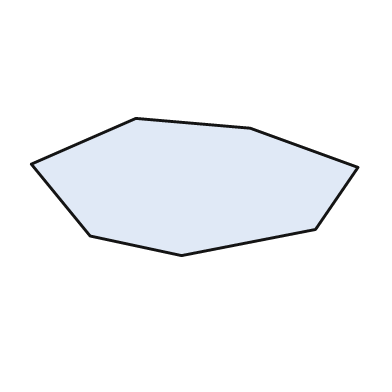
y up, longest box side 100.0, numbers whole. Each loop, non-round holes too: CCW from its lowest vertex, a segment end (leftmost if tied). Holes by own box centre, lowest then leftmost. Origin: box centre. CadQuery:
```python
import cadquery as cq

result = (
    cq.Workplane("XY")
    .moveTo(-4.0, -21.0)
    .lineTo(37.0, -13.0)
    .lineTo(50.0, 6.0)
    .lineTo(17.0, 18.0)
    .lineTo(-18.0, 21.0)
    .lineTo(-50.0, 7.0)
    .lineTo(-32.0, -15.0)
    .close()
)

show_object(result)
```